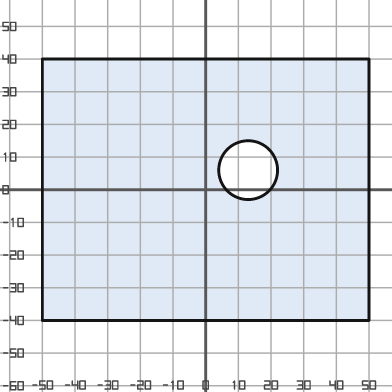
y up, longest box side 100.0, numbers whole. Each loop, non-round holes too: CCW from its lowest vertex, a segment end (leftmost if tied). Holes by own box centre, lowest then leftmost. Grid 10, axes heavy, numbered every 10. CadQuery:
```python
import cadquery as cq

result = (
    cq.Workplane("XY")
    .moveTo(-50.0, -40.0)
    .lineTo(50.0, -40.0)
    .lineTo(50.0, 40.0)
    .lineTo(-50.0, 40.0)
    .close()
    .moveTo(13.0, 6.0)
    .circle(9.0)
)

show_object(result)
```